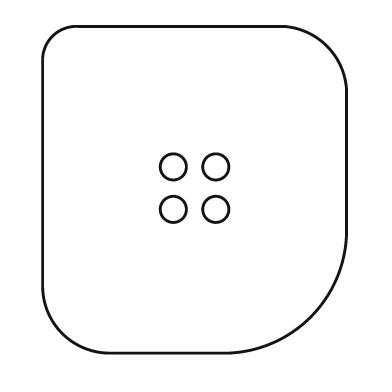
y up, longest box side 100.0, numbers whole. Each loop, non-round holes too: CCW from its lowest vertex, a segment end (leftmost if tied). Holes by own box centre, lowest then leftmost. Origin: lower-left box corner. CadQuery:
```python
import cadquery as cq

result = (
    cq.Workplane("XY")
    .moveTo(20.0, 0.0)
    .lineTo(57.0, 0.0)
    .threePointArc((82.0, 11.0), (93.0, 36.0))
    .lineTo(93.0, 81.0)
    .threePointArc((87.0, 94.0), (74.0, 100.0))
    .lineTo(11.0, 100.0)
    .threePointArc((3.0, 97.0), (0.0, 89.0))
    .lineTo(0.0, 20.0)
    .threePointArc((6.0, 6.0), (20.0, 0.0))
    .close()
    .moveTo(40.0, 44.0)
    .circle(4.0)
    .moveTo(53.0, 44.0)
    .circle(4.0)
    .moveTo(40.0, 57.0)
    .circle(4.0)
    .moveTo(53.0, 57.0)
    .circle(4.0)
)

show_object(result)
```